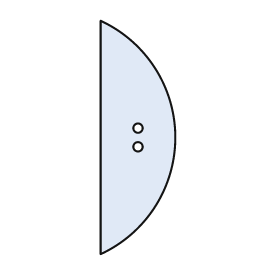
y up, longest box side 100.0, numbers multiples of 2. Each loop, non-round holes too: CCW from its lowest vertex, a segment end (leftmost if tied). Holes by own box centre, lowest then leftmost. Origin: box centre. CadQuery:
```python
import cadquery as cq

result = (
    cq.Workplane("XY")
    .moveTo(-16.0, -50.0)
    .threePointArc((16.0, 0.0), (-16.0, 50.0))
    .close()
    .moveTo(0.0, -4.0)
    .circle(2.0)
    .moveTo(0.0, 4.0)
    .circle(2.0)
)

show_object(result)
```